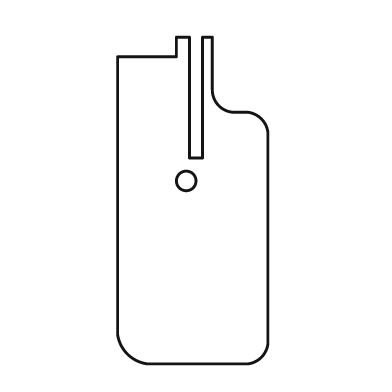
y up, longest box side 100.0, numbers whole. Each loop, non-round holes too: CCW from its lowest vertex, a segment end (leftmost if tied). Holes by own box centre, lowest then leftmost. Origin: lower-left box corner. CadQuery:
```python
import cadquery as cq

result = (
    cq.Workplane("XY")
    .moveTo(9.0, 0.0)
    .lineTo(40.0, 0.0)
    .threePointArc((44.0, 2.0), (46.0, 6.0))
    .lineTo(46.0, 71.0)
    .threePointArc((44.0, 75.0), (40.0, 77.0))
    .lineTo(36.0, 77.0)
    .threePointArc((31.0, 79.0), (29.0, 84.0))
    .lineTo(29.0, 100.0)
    .lineTo(26.0, 100.0)
    .lineTo(26.0, 63.0)
    .lineTo(22.0, 63.0)
    .lineTo(22.0, 100.0)
    .lineTo(18.0, 100.0)
    .lineTo(18.0, 94.0)
    .lineTo(0.0, 94.0)
    .lineTo(0.0, 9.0)
    .threePointArc((3.0, 3.0), (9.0, 0.0))
    .close()
    .moveTo(21.0, 56.0)
    .circle(3.0)
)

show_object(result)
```